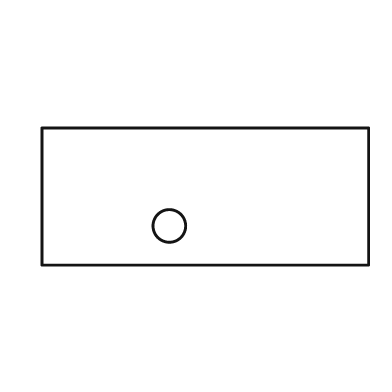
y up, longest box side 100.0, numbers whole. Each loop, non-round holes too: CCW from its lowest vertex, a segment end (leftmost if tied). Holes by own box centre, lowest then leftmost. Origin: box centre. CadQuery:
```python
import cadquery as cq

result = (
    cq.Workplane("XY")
    .moveTo(-50.0, -21.0)
    .lineTo(50.0, -21.0)
    .lineTo(50.0, 21.0)
    .lineTo(-50.0, 21.0)
    .close()
    .moveTo(-11.0, -9.0)
    .circle(5.0)
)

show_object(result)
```